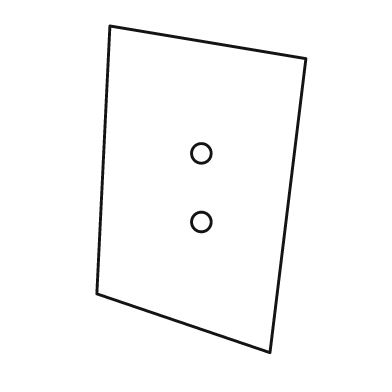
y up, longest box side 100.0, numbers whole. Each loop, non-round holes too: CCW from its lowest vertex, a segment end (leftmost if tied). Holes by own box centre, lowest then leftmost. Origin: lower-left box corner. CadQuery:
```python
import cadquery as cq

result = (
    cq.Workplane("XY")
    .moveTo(53.0, 0.0)
    .lineTo(64.0, 90.0)
    .lineTo(4.0, 100.0)
    .lineTo(0.0, 18.0)
    .close()
    .moveTo(32.0, 40.0)
    .circle(3.0)
    .moveTo(32.0, 61.0)
    .circle(3.0)
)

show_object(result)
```